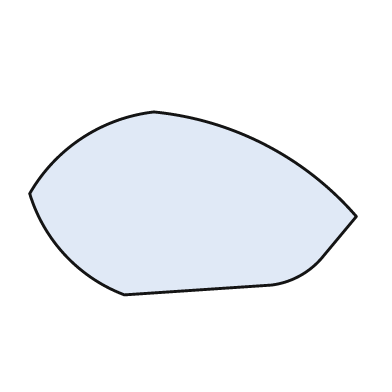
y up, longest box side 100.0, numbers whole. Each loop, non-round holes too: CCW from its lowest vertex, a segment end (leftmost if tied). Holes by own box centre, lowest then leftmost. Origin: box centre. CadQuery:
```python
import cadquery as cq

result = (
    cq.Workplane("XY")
    .moveTo(-21.0, -28.0)
    .lineTo(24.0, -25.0)
    .threePointArc((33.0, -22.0), (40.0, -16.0))
    .lineTo(50.0, -4.0)
    .threePointArc((22.0, 18.0), (-12.0, 28.0))
    .threePointArc((-34.0, 20.0), (-50.0, 3.0))
    .threePointArc((-39.0, -16.0), (-21.0, -28.0))
    .close()
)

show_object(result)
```